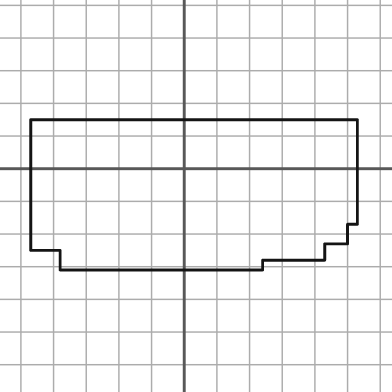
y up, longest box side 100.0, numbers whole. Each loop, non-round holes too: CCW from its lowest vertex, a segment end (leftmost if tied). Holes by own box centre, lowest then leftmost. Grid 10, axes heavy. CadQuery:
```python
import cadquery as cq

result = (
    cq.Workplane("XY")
    .moveTo(-38.0, -31.0)
    .lineTo(24.0, -31.0)
    .lineTo(24.0, -28.0)
    .lineTo(43.0, -28.0)
    .lineTo(43.0, -23.0)
    .lineTo(50.0, -23.0)
    .lineTo(50.0, -17.0)
    .lineTo(53.0, -17.0)
    .lineTo(53.0, 15.0)
    .lineTo(-47.0, 15.0)
    .lineTo(-47.0, -25.0)
    .lineTo(-38.0, -25.0)
    .close()
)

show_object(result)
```